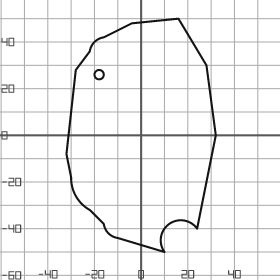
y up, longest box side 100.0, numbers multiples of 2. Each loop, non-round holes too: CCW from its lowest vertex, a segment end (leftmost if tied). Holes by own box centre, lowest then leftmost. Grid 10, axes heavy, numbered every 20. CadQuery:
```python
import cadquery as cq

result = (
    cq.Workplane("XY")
    .moveTo(10.0, -50.0)
    .threePointArc((12.0, -38.0), (24.0, -40.0))
    .lineTo(32.0, 0.0)
    .lineTo(28.0, 30.0)
    .lineTo(16.0, 50.0)
    .lineTo(-4.0, 48.0)
    .lineTo(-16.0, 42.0)
    .threePointArc((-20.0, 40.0), (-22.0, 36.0))
    .lineTo(-28.0, 28.0)
    .lineTo(-32.0, -8.0)
    .lineTo(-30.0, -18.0)
    .threePointArc((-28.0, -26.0), (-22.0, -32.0))
    .lineTo(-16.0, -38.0)
    .threePointArc((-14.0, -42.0), (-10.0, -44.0))
    .close()
    .moveTo(-18.0, 26.0)
    .circle(2.0)
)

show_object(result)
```